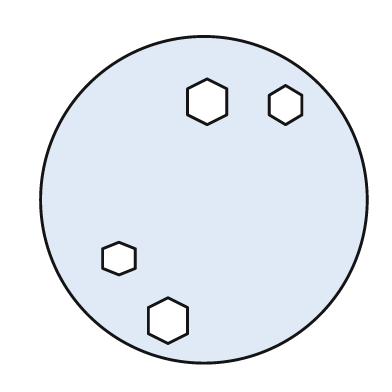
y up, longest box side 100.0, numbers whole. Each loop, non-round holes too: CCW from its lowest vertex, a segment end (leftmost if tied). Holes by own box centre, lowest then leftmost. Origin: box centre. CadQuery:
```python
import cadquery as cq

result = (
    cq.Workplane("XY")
    .moveTo(0.0, 0.0)
    .circle(50.0)
    .moveTo(-11.0, -44.0)
    .lineTo(-5.0, -41.0)
    .lineTo(-5.0, -33.0)
    .lineTo(-11.0, -30.0)
    .lineTo(-17.0, -33.0)
    .lineTo(-17.0, -41.0)
    .close()
    .moveTo(-26.0, -23.0)
    .lineTo(-21.0, -21.0)
    .lineTo(-21.0, -15.0)
    .lineTo(-26.0, -13.0)
    .lineTo(-31.0, -15.0)
    .lineTo(-31.0, -21.0)
    .close()
    .moveTo(25.0, 23.0)
    .lineTo(30.0, 26.0)
    .lineTo(30.0, 32.0)
    .lineTo(25.0, 35.0)
    .lineTo(20.0, 32.0)
    .lineTo(20.0, 26.0)
    .close()
    .moveTo(1.0, 23.0)
    .lineTo(7.0, 26.0)
    .lineTo(7.0, 34.0)
    .lineTo(1.0, 37.0)
    .lineTo(-5.0, 34.0)
    .lineTo(-5.0, 26.0)
    .close()
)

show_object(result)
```